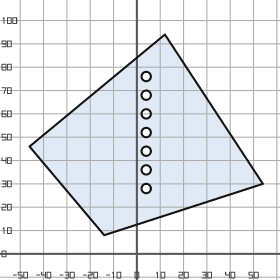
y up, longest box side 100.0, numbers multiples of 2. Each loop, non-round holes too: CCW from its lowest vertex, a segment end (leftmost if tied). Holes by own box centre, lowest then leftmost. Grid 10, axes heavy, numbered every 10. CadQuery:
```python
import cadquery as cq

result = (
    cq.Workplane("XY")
    .moveTo(-14.0, 8.0)
    .lineTo(54.0, 30.0)
    .lineTo(12.0, 94.0)
    .lineTo(-46.0, 46.0)
    .close()
    .moveTo(4.0, 28.0)
    .circle(2.0)
    .moveTo(4.0, 36.0)
    .circle(2.0)
    .moveTo(4.0, 44.0)
    .circle(2.0)
    .moveTo(4.0, 52.0)
    .circle(2.0)
    .moveTo(4.0, 60.0)
    .circle(2.0)
    .moveTo(4.0, 68.0)
    .circle(2.0)
    .moveTo(4.0, 76.0)
    .circle(2.0)
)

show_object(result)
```